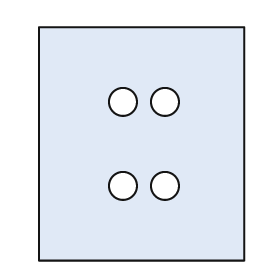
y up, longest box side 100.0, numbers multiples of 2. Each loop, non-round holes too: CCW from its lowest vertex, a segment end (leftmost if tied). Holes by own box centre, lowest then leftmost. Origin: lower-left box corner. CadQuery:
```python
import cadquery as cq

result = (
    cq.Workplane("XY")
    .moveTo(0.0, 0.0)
    .lineTo(88.0, 0.0)
    .lineTo(88.0, 100.0)
    .lineTo(0.0, 100.0)
    .close()
    .moveTo(36.0, 32.0)
    .circle(6.0)
    .moveTo(54.0, 32.0)
    .circle(6.0)
    .moveTo(36.0, 68.0)
    .circle(6.0)
    .moveTo(54.0, 68.0)
    .circle(6.0)
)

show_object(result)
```